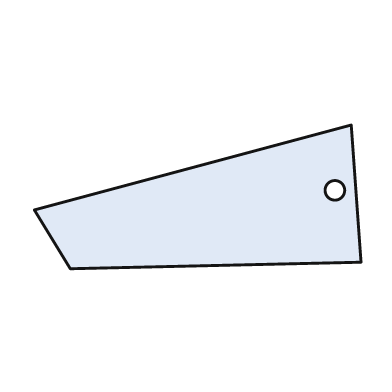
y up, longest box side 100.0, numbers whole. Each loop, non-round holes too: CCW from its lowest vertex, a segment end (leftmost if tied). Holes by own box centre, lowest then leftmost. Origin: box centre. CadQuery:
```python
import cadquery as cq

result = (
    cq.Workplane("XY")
    .moveTo(-39.0, -22.0)
    .lineTo(50.0, -20.0)
    .lineTo(47.0, 22.0)
    .lineTo(-50.0, -4.0)
    .close()
    .moveTo(42.0, 2.0)
    .circle(3.0)
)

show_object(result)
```